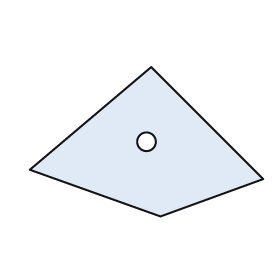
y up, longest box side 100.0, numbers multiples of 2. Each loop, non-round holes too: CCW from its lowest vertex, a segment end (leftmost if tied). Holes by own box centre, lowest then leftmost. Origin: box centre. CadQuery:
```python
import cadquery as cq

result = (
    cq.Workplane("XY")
    .moveTo(6.0, -32.0)
    .lineTo(50.0, -16.0)
    .lineTo(2.0, 32.0)
    .lineTo(-50.0, -12.0)
    .close()
    .moveTo(0.0, 0.0)
    .circle(4.0)
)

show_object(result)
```